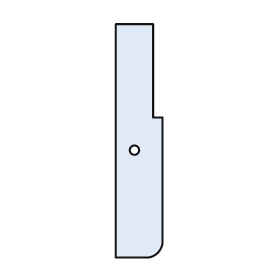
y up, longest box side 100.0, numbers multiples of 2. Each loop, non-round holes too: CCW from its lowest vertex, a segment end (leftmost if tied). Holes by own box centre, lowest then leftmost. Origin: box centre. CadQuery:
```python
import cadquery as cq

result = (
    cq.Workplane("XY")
    .moveTo(-10.0, -50.0)
    .lineTo(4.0, -50.0)
    .threePointArc((8.0, -48.0), (10.0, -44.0))
    .lineTo(10.0, 10.0)
    .lineTo(6.0, 10.0)
    .lineTo(6.0, 50.0)
    .lineTo(-10.0, 50.0)
    .close()
    .moveTo(-2.0, -4.0)
    .circle(2.0)
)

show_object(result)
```